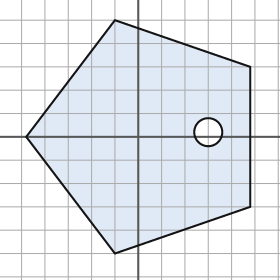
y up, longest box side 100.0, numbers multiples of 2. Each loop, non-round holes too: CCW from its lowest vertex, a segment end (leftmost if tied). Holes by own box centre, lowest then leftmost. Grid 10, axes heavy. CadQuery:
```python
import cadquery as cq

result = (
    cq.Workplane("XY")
    .moveTo(-10.0, -50.0)
    .lineTo(48.0, -30.0)
    .lineTo(48.0, 30.0)
    .lineTo(-10.0, 50.0)
    .lineTo(-48.0, 0.0)
    .close()
    .moveTo(30.0, 2.0)
    .circle(6.0)
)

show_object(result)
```